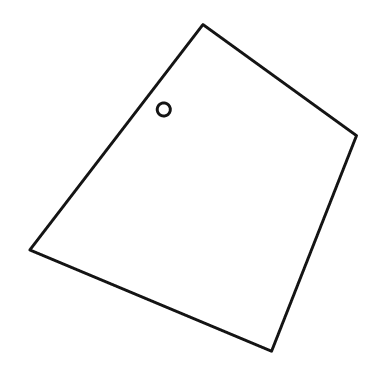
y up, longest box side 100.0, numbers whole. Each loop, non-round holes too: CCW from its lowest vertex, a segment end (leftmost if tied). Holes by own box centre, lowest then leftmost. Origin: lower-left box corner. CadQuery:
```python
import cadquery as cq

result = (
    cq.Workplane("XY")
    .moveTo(74.0, 0.0)
    .lineTo(100.0, 66.0)
    .lineTo(53.0, 100.0)
    .lineTo(0.0, 31.0)
    .close()
    .moveTo(41.0, 74.0)
    .circle(2.0)
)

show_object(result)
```